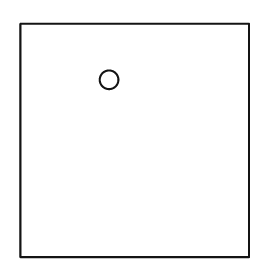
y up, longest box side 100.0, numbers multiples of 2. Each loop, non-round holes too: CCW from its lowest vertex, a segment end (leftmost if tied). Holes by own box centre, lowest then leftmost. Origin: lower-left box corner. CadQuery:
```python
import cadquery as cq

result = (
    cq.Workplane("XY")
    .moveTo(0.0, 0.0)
    .lineTo(98.0, 0.0)
    .lineTo(98.0, 100.0)
    .lineTo(0.0, 100.0)
    .close()
    .moveTo(38.0, 76.0)
    .circle(4.0)
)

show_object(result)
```